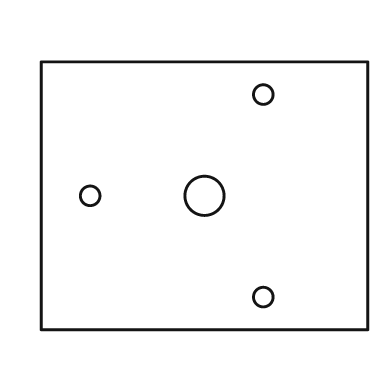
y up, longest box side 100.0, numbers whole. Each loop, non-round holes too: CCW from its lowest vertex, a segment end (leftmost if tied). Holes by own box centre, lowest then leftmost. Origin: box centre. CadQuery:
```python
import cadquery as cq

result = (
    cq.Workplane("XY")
    .moveTo(-50.0, -41.0)
    .lineTo(50.0, -41.0)
    .lineTo(50.0, 41.0)
    .lineTo(-50.0, 41.0)
    .close()
    .moveTo(18.0, -31.0)
    .circle(3.0)
    .moveTo(-35.0, 0.0)
    .circle(3.0)
    .moveTo(0.0, 0.0)
    .circle(6.0)
    .moveTo(18.0, 31.0)
    .circle(3.0)
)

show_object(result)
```